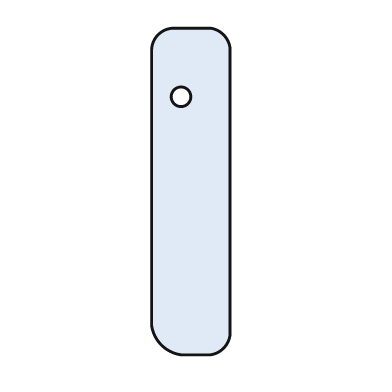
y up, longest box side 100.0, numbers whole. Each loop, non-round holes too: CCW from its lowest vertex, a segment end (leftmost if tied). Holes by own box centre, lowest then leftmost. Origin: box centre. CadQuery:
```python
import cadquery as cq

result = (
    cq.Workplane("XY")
    .moveTo(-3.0, -50.0)
    .lineTo(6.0, -50.0)
    .threePointArc((10.0, -48.0), (12.0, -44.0))
    .lineTo(12.0, 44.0)
    .threePointArc((10.0, 48.0), (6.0, 50.0))
    .lineTo(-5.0, 50.0)
    .threePointArc((-10.0, 48.0), (-12.0, 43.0))
    .lineTo(-12.0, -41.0)
    .threePointArc((-9.0, -47.0), (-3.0, -50.0))
    .close()
    .moveTo(-3.0, 29.0)
    .circle(3.0)
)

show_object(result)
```